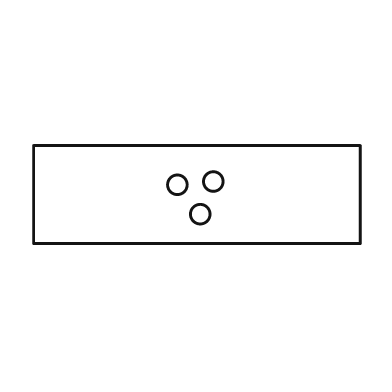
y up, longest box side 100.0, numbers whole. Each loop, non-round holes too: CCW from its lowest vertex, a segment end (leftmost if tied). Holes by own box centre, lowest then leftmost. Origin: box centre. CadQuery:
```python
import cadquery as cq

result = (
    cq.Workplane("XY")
    .moveTo(-50.0, -15.0)
    .lineTo(50.0, -15.0)
    .lineTo(50.0, 15.0)
    .lineTo(-50.0, 15.0)
    .close()
    .moveTo(1.0, -6.0)
    .circle(3.0)
    .moveTo(-6.0, 3.0)
    .circle(3.0)
    .moveTo(5.0, 4.0)
    .circle(3.0)
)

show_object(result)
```